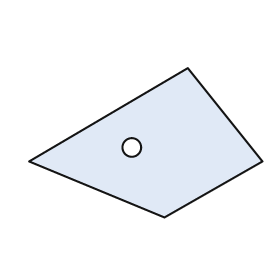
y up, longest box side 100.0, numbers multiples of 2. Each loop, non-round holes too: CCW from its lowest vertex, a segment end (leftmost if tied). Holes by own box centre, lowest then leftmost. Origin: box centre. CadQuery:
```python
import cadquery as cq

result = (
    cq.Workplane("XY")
    .moveTo(8.0, -32.0)
    .lineTo(50.0, -8.0)
    .lineTo(18.0, 32.0)
    .lineTo(-50.0, -8.0)
    .close()
    .moveTo(-6.0, -2.0)
    .circle(4.0)
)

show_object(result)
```